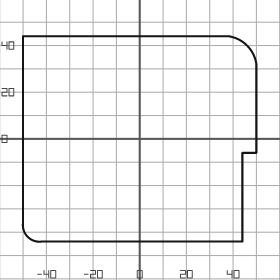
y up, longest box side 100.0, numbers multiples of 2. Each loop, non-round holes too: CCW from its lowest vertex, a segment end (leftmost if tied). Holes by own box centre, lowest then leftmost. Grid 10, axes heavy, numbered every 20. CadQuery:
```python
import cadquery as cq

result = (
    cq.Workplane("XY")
    .moveTo(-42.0, -44.0)
    .lineTo(44.0, -44.0)
    .lineTo(44.0, -6.0)
    .lineTo(50.0, -6.0)
    .lineTo(50.0, 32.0)
    .threePointArc((46.0, 40.0), (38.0, 44.0))
    .lineTo(-50.0, 44.0)
    .lineTo(-50.0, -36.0)
    .threePointArc((-48.0, -42.0), (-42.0, -44.0))
    .close()
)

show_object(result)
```